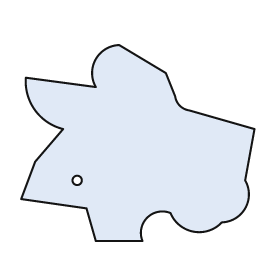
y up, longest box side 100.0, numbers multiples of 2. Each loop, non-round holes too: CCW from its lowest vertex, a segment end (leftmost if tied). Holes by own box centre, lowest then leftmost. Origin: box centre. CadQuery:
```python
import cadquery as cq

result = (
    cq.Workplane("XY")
    .moveTo(-18.0, -42.0)
    .lineTo(2.0, -42.0)
    .threePointArc((4.0, -32.0), (14.0, -30.0))
    .threePointArc((24.0, -38.0), (36.0, -34.0))
    .threePointArc((46.0, -28.0), (46.0, -16.0))
    .lineTo(50.0, 6.0)
    .lineTo(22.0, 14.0)
    .threePointArc((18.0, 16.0), (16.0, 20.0))
    .lineTo(12.0, 30.0)
    .lineTo(-8.0, 42.0)
    .threePointArc((-18.0, 36.0), (-18.0, 24.0))
    .lineTo(-48.0, 28.0)
    .threePointArc((-44.0, 14.0), (-32.0, 6.0))
    .lineTo(-44.0, -8.0)
    .lineTo(-50.0, -24.0)
    .lineTo(-22.0, -28.0)
    .close()
    .moveTo(-26.0, -16.0)
    .circle(2.0)
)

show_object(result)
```